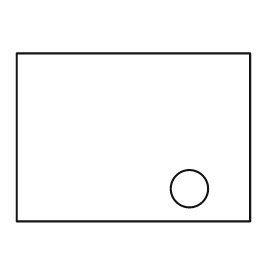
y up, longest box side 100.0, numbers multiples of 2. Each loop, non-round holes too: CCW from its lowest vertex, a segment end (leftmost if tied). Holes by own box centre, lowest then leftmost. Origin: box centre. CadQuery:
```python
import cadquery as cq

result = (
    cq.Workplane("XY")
    .moveTo(-50.0, -36.0)
    .lineTo(50.0, -36.0)
    .lineTo(50.0, 36.0)
    .lineTo(-50.0, 36.0)
    .close()
    .moveTo(24.0, -22.0)
    .circle(8.0)
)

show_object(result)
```